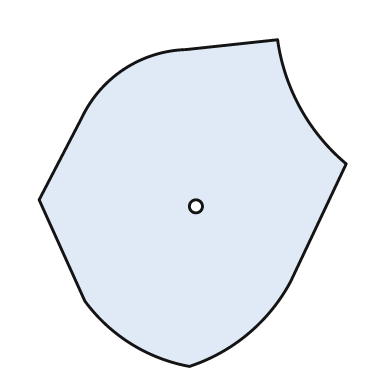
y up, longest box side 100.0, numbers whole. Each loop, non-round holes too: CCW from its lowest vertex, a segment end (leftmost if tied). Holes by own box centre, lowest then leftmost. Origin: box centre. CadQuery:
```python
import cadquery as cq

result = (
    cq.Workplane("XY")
    .moveTo(-1.0, -50.0)
    .threePointArc((17.0, -40.0), (30.0, -24.0))
    .lineTo(47.0, 12.0)
    .threePointArc((33.0, 29.0), (26.0, 50.0))
    .lineTo(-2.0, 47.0)
    .threePointArc((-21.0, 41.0), (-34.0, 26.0))
    .lineTo(-47.0, 1.0)
    .lineTo(-33.0, -30.0)
    .threePointArc((-19.0, -43.0), (-1.0, -50.0))
    .close()
    .moveTo(1.0, -1.0)
    .circle(2.0)
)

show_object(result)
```